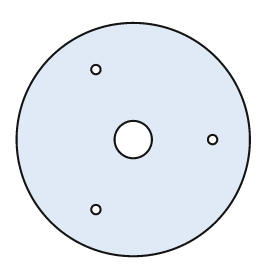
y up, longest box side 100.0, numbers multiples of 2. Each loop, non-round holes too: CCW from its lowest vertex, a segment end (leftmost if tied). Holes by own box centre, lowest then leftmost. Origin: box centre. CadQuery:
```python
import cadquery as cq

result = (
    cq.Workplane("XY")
    .moveTo(0.0, 0.0)
    .circle(50.0)
    .moveTo(-16.0, -30.0)
    .circle(2.0)
    .moveTo(0.0, 0.0)
    .circle(8.0)
    .moveTo(34.0, 0.0)
    .circle(2.0)
    .moveTo(-16.0, 30.0)
    .circle(2.0)
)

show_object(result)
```